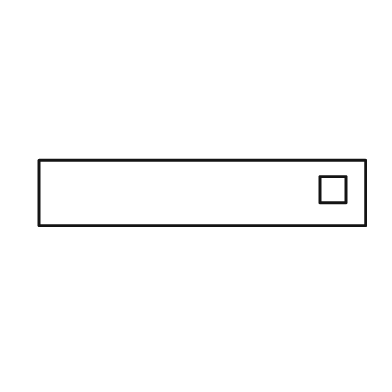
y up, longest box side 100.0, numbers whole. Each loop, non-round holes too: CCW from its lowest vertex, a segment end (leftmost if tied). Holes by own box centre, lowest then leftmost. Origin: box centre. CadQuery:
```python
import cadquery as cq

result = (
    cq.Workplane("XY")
    .moveTo(-50.0, -10.0)
    .lineTo(50.0, -10.0)
    .lineTo(50.0, 10.0)
    .lineTo(-50.0, 10.0)
    .close()
    .moveTo(36.0, -3.0)
    .lineTo(44.0, -3.0)
    .lineTo(44.0, 5.0)
    .lineTo(36.0, 5.0)
    .close()
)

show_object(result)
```